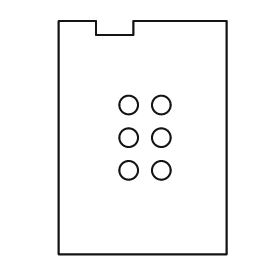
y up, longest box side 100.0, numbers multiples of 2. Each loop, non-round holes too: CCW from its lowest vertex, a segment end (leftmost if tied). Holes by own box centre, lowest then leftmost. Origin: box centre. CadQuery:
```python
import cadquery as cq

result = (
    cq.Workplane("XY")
    .moveTo(-36.0, -50.0)
    .lineTo(36.0, -50.0)
    .lineTo(36.0, 50.0)
    .lineTo(-4.0, 50.0)
    .lineTo(-4.0, 44.0)
    .lineTo(-20.0, 44.0)
    .lineTo(-20.0, 50.0)
    .lineTo(-36.0, 50.0)
    .close()
    .moveTo(-6.0, -14.0)
    .circle(4.0)
    .moveTo(8.0, -14.0)
    .circle(4.0)
    .moveTo(-6.0, 0.0)
    .circle(4.0)
    .moveTo(8.0, 0.0)
    .circle(4.0)
    .moveTo(-6.0, 14.0)
    .circle(4.0)
    .moveTo(8.0, 14.0)
    .circle(4.0)
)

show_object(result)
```